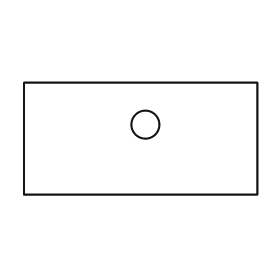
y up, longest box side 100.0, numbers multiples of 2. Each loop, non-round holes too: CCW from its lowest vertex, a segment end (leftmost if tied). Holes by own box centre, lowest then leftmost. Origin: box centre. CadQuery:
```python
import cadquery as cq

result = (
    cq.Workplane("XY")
    .moveTo(-50.0, -24.0)
    .lineTo(50.0, -24.0)
    .lineTo(50.0, 24.0)
    .lineTo(-50.0, 24.0)
    .close()
    .moveTo(2.0, 6.0)
    .circle(6.0)
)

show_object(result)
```